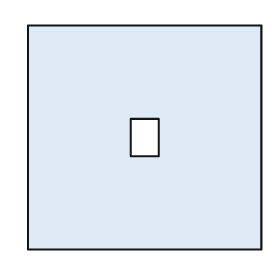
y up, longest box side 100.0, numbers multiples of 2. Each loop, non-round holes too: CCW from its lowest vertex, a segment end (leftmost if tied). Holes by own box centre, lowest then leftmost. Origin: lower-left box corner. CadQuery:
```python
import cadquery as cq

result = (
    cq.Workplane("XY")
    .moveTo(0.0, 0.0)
    .lineTo(100.0, 0.0)
    .lineTo(100.0, 96.0)
    .lineTo(0.0, 96.0)
    .close()
    .moveTo(44.0, 40.0)
    .lineTo(56.0, 40.0)
    .lineTo(56.0, 56.0)
    .lineTo(44.0, 56.0)
    .close()
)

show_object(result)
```